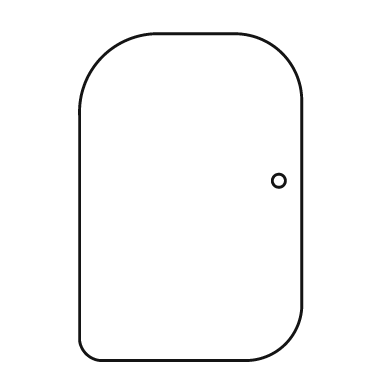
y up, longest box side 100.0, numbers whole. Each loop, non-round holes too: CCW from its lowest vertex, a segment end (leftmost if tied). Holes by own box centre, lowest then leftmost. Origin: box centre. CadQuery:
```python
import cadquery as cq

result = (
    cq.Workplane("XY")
    .moveTo(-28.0, -50.0)
    .lineTo(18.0, -50.0)
    .threePointArc((29.0, -45.0), (34.0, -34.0))
    .lineTo(34.0, 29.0)
    .threePointArc((28.0, 44.0), (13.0, 50.0))
    .lineTo(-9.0, 50.0)
    .threePointArc((-27.0, 43.0), (-34.0, 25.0))
    .lineTo(-34.0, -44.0)
    .threePointArc((-32.0, -48.0), (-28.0, -50.0))
    .close()
    .moveTo(27.0, 5.0)
    .circle(2.0)
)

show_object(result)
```